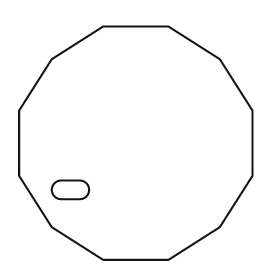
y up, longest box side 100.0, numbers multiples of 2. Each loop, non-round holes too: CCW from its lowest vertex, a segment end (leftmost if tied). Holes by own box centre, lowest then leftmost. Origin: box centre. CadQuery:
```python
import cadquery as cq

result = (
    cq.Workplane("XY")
    .moveTo(-14.0, -50.0)
    .lineTo(14.0, -50.0)
    .lineTo(36.0, -36.0)
    .lineTo(50.0, -14.0)
    .lineTo(50.0, 14.0)
    .lineTo(36.0, 36.0)
    .lineTo(14.0, 50.0)
    .lineTo(-14.0, 50.0)
    .lineTo(-36.0, 36.0)
    .lineTo(-50.0, 14.0)
    .lineTo(-50.0, -14.0)
    .lineTo(-36.0, -36.0)
    .close()
    .moveTo(-32.0, -24.0)
    .lineTo(-24.0, -24.0)
    .threePointArc((-20.0, -20.0), (-24.0, -16.0))
    .lineTo(-32.0, -16.0)
    .threePointArc((-36.0, -20.0), (-32.0, -24.0))
    .close()
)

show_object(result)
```